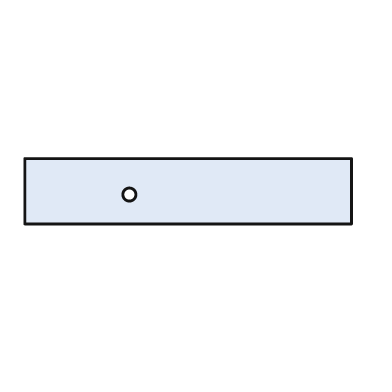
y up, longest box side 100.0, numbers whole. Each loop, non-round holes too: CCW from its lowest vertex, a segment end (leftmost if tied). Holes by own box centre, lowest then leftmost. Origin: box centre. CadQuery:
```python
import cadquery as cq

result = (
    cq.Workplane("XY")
    .moveTo(-50.0, -10.0)
    .lineTo(50.0, -10.0)
    .lineTo(50.0, 10.0)
    .lineTo(-50.0, 10.0)
    .close()
    .moveTo(-18.0, -1.0)
    .circle(2.0)
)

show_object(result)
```